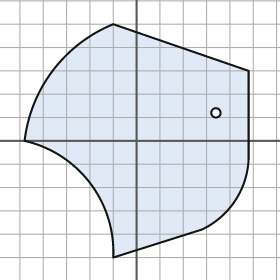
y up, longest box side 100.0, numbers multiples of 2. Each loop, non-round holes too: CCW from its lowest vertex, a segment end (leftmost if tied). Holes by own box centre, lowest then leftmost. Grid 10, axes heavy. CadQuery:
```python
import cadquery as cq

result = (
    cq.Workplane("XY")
    .moveTo(-10.0, -50.0)
    .lineTo(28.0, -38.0)
    .threePointArc((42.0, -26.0), (48.0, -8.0))
    .lineTo(48.0, 30.0)
    .lineTo(-10.0, 50.0)
    .threePointArc((-36.0, 30.0), (-48.0, 0.0))
    .threePointArc((-20.0, -18.0), (-10.0, -50.0))
    .close()
    .moveTo(34.0, 12.0)
    .circle(2.0)
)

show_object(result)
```